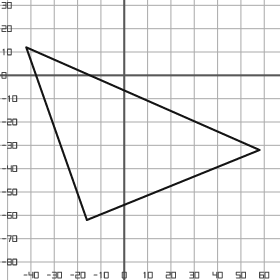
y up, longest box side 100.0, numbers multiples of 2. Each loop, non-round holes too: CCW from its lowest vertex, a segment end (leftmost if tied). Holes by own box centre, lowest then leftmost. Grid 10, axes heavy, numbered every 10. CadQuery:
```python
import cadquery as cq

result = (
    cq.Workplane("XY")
    .moveTo(-16.0, -62.0)
    .lineTo(58.0, -32.0)
    .lineTo(-42.0, 12.0)
    .close()
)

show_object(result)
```